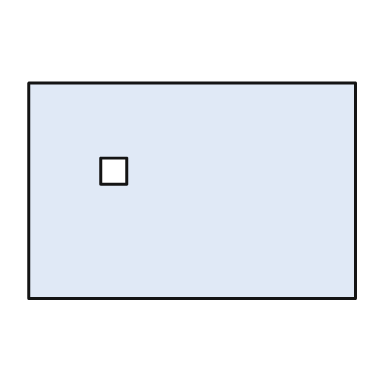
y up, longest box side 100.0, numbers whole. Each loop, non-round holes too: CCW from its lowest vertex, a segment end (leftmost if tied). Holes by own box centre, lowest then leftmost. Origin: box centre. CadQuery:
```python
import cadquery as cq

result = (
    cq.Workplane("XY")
    .moveTo(-50.0, -33.0)
    .lineTo(50.0, -33.0)
    .lineTo(50.0, 33.0)
    .lineTo(-50.0, 33.0)
    .close()
    .moveTo(-28.0, 2.0)
    .lineTo(-20.0, 2.0)
    .lineTo(-20.0, 10.0)
    .lineTo(-28.0, 10.0)
    .close()
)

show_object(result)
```